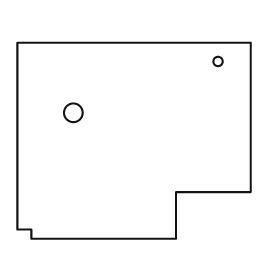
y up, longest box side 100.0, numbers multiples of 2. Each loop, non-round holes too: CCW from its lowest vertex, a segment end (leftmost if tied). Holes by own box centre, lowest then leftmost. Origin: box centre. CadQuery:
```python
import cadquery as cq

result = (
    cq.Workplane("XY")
    .moveTo(-44.0, -42.0)
    .lineTo(18.0, -42.0)
    .lineTo(18.0, -22.0)
    .lineTo(50.0, -22.0)
    .lineTo(50.0, 42.0)
    .lineTo(-50.0, 42.0)
    .lineTo(-50.0, -38.0)
    .lineTo(-44.0, -38.0)
    .close()
    .moveTo(-26.0, 12.0)
    .circle(4.0)
    .moveTo(36.0, 34.0)
    .circle(2.0)
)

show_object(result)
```